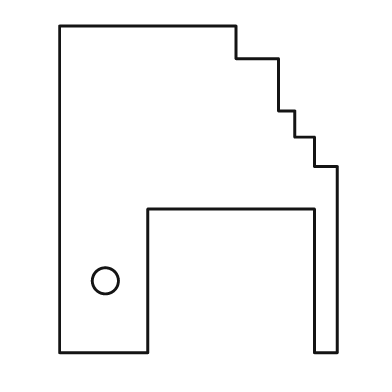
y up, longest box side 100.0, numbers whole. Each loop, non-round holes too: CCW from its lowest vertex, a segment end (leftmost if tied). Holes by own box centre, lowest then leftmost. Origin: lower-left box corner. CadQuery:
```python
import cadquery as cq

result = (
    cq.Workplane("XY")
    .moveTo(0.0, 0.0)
    .lineTo(27.0, 0.0)
    .lineTo(27.0, 44.0)
    .lineTo(78.0, 44.0)
    .lineTo(78.0, 0.0)
    .lineTo(85.0, 0.0)
    .lineTo(85.0, 57.0)
    .lineTo(78.0, 57.0)
    .lineTo(78.0, 66.0)
    .lineTo(72.0, 66.0)
    .lineTo(72.0, 74.0)
    .lineTo(67.0, 74.0)
    .lineTo(67.0, 90.0)
    .lineTo(54.0, 90.0)
    .lineTo(54.0, 100.0)
    .lineTo(0.0, 100.0)
    .close()
    .moveTo(14.0, 22.0)
    .circle(4.0)
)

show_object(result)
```